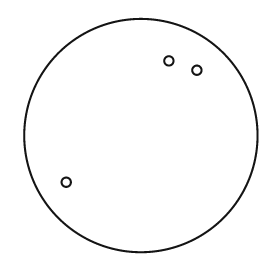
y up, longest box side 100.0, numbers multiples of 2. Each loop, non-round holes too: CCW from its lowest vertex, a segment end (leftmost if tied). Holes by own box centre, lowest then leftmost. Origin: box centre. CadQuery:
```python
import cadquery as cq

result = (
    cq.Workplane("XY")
    .moveTo(0.0, 0.0)
    .circle(50.0)
    .moveTo(-32.0, -20.0)
    .circle(2.0)
    .moveTo(24.0, 28.0)
    .circle(2.0)
    .moveTo(12.0, 32.0)
    .circle(2.0)
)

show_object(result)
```